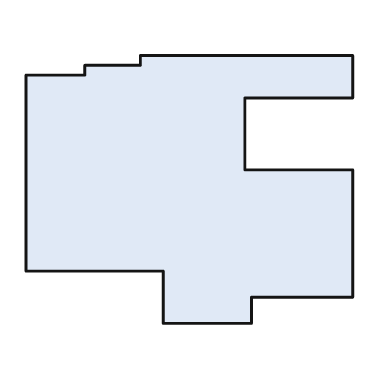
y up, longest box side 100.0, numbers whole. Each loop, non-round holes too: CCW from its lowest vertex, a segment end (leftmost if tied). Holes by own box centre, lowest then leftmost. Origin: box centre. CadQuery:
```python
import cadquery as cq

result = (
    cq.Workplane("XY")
    .moveTo(-8.0, -41.0)
    .lineTo(19.0, -41.0)
    .lineTo(19.0, -33.0)
    .lineTo(50.0, -33.0)
    .lineTo(50.0, 6.0)
    .lineTo(17.0, 6.0)
    .lineTo(17.0, 28.0)
    .lineTo(50.0, 28.0)
    .lineTo(50.0, 41.0)
    .lineTo(-15.0, 41.0)
    .lineTo(-15.0, 38.0)
    .lineTo(-32.0, 38.0)
    .lineTo(-32.0, 35.0)
    .lineTo(-50.0, 35.0)
    .lineTo(-50.0, -25.0)
    .lineTo(-8.0, -25.0)
    .close()
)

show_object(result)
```